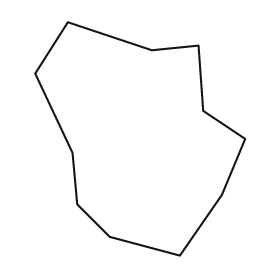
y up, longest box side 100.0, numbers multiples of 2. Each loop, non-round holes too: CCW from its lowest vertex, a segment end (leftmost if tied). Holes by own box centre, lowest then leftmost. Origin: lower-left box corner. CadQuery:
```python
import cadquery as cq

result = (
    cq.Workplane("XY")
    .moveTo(62.0, 0.0)
    .lineTo(80.0, 26.0)
    .lineTo(90.0, 50.0)
    .lineTo(72.0, 62.0)
    .lineTo(70.0, 90.0)
    .lineTo(50.0, 88.0)
    .lineTo(14.0, 100.0)
    .lineTo(0.0, 78.0)
    .lineTo(16.0, 44.0)
    .lineTo(18.0, 22.0)
    .lineTo(32.0, 8.0)
    .close()
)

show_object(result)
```